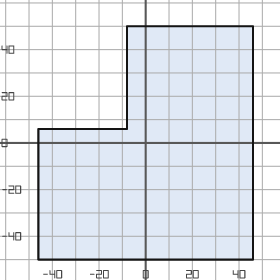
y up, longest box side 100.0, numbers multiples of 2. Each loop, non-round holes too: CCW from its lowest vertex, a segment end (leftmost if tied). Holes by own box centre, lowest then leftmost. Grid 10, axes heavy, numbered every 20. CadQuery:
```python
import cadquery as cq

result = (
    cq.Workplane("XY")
    .moveTo(-46.0, -50.0)
    .lineTo(46.0, -50.0)
    .lineTo(46.0, 50.0)
    .lineTo(-8.0, 50.0)
    .lineTo(-8.0, 6.0)
    .lineTo(-46.0, 6.0)
    .close()
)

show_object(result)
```